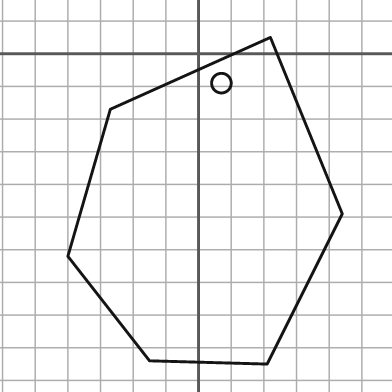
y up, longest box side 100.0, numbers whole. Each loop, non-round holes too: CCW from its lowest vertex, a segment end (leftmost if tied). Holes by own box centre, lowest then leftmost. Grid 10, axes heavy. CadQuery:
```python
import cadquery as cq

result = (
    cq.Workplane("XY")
    .moveTo(21.0, -95.0)
    .lineTo(44.0, -49.0)
    .lineTo(22.0, 5.0)
    .lineTo(-27.0, -17.0)
    .lineTo(-40.0, -62.0)
    .lineTo(-15.0, -94.0)
    .close()
    .moveTo(7.0, -9.0)
    .circle(3.0)
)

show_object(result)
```